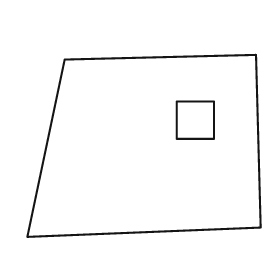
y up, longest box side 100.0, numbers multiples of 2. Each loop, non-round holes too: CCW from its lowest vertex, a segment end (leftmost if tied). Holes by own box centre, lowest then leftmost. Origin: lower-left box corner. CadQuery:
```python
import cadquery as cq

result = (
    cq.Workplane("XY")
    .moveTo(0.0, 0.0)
    .lineTo(100.0, 4.0)
    .lineTo(98.0, 78.0)
    .lineTo(16.0, 76.0)
    .close()
    .moveTo(64.0, 42.0)
    .lineTo(80.0, 42.0)
    .lineTo(80.0, 58.0)
    .lineTo(64.0, 58.0)
    .close()
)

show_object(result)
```